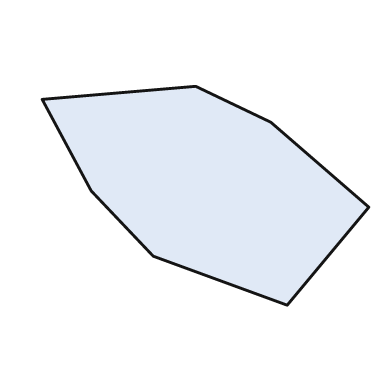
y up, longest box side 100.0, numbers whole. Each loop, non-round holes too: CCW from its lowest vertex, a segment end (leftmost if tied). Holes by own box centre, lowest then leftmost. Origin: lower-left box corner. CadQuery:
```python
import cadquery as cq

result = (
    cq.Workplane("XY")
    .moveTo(75.0, 0.0)
    .lineTo(100.0, 30.0)
    .lineTo(70.0, 56.0)
    .lineTo(47.0, 67.0)
    .lineTo(0.0, 63.0)
    .lineTo(15.0, 35.0)
    .lineTo(34.0, 15.0)
    .close()
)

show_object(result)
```